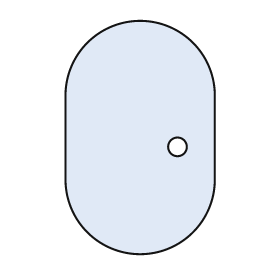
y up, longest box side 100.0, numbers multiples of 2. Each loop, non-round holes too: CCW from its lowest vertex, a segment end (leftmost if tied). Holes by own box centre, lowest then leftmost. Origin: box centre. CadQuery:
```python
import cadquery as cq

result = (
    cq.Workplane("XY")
    .moveTo(-32.0, -18.0)
    .threePointArc((0.0, -50.0), (32.0, -18.0))
    .lineTo(32.0, 18.0)
    .threePointArc((0.0, 50.0), (-32.0, 18.0))
    .close()
    .moveTo(16.0, -4.0)
    .circle(4.0)
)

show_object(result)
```